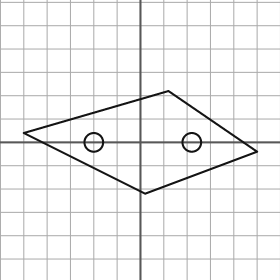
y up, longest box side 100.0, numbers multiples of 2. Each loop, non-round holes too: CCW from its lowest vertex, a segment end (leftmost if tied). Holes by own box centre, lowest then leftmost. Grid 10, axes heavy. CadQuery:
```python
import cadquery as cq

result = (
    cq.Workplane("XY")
    .moveTo(2.0, -22.0)
    .lineTo(50.0, -4.0)
    .lineTo(12.0, 22.0)
    .lineTo(-50.0, 4.0)
    .close()
    .moveTo(-20.0, 0.0)
    .circle(4.0)
    .moveTo(22.0, 0.0)
    .circle(4.0)
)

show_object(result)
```